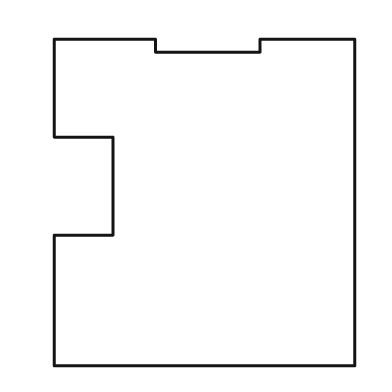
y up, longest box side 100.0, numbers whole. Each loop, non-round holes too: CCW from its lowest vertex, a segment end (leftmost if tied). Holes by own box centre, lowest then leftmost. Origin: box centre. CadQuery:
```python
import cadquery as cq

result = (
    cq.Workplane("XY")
    .moveTo(-46.0, -50.0)
    .lineTo(46.0, -50.0)
    .lineTo(46.0, 50.0)
    .lineTo(17.0, 50.0)
    .lineTo(17.0, 46.0)
    .lineTo(-15.0, 46.0)
    .lineTo(-15.0, 50.0)
    .lineTo(-46.0, 50.0)
    .lineTo(-46.0, 20.0)
    .lineTo(-28.0, 20.0)
    .lineTo(-28.0, -10.0)
    .lineTo(-46.0, -10.0)
    .close()
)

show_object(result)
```